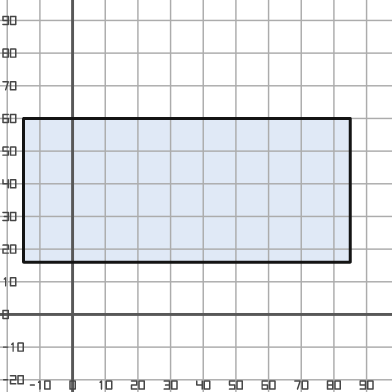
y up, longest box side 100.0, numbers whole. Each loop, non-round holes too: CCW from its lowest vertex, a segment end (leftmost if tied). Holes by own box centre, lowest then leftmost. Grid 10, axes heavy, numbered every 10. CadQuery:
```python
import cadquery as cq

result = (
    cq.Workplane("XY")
    .moveTo(-15.0, 16.0)
    .lineTo(85.0, 16.0)
    .lineTo(85.0, 60.0)
    .lineTo(-15.0, 60.0)
    .close()
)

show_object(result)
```